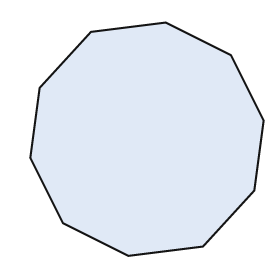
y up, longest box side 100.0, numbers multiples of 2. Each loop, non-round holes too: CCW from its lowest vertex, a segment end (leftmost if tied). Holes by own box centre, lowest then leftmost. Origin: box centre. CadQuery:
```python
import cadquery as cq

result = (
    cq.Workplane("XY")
    .moveTo(-8.0, -50.0)
    .lineTo(24.0, -46.0)
    .lineTo(46.0, -22.0)
    .lineTo(50.0, 8.0)
    .lineTo(36.0, 36.0)
    .lineTo(8.0, 50.0)
    .lineTo(-24.0, 46.0)
    .lineTo(-46.0, 22.0)
    .lineTo(-50.0, -8.0)
    .lineTo(-36.0, -36.0)
    .close()
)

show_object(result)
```